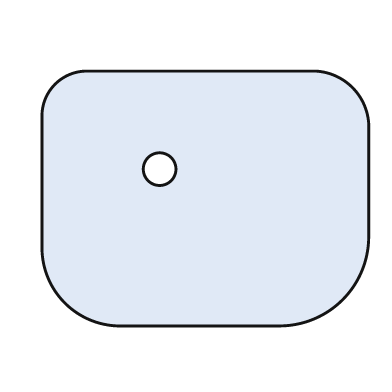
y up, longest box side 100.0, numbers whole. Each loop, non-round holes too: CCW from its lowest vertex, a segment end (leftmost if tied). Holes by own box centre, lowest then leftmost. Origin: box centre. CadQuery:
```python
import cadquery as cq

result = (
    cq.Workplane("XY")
    .moveTo(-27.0, -39.0)
    .lineTo(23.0, -39.0)
    .threePointArc((42.0, -31.0), (50.0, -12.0))
    .lineTo(50.0, 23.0)
    .threePointArc((45.0, 34.0), (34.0, 39.0))
    .lineTo(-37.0, 39.0)
    .threePointArc((-46.0, 35.0), (-50.0, 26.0))
    .lineTo(-50.0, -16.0)
    .threePointArc((-43.0, -32.0), (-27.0, -39.0))
    .close()
    .moveTo(-14.0, 9.0)
    .circle(5.0)
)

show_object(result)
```